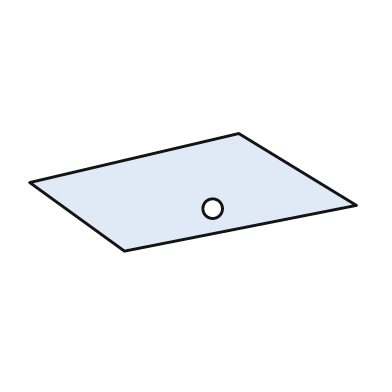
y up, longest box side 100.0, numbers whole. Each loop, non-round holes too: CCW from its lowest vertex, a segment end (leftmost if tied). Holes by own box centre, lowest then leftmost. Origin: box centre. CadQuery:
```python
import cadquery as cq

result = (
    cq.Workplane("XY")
    .moveTo(-21.0, -18.0)
    .lineTo(50.0, -4.0)
    .lineTo(14.0, 18.0)
    .lineTo(-50.0, 3.0)
    .close()
    .moveTo(6.0, -5.0)
    .circle(3.0)
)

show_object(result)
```